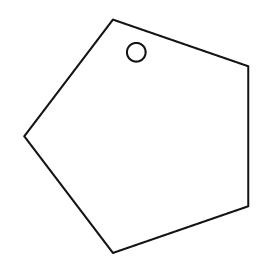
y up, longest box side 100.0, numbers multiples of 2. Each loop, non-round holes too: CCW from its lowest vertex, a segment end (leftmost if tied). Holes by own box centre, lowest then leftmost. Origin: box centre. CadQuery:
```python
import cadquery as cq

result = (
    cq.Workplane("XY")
    .moveTo(-10.0, -50.0)
    .lineTo(48.0, -30.0)
    .lineTo(48.0, 30.0)
    .lineTo(-10.0, 50.0)
    .lineTo(-48.0, 0.0)
    .close()
    .moveTo(0.0, 36.0)
    .circle(4.0)
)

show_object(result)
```